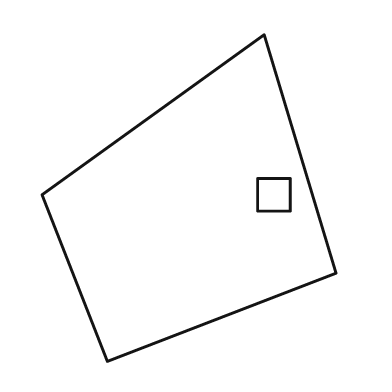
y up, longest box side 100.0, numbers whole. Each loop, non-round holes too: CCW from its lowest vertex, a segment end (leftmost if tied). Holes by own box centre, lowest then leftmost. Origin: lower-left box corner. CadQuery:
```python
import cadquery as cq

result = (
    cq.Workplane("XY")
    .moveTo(20.0, 0.0)
    .lineTo(90.0, 27.0)
    .lineTo(68.0, 100.0)
    .lineTo(0.0, 51.0)
    .close()
    .moveTo(66.0, 46.0)
    .lineTo(76.0, 46.0)
    .lineTo(76.0, 56.0)
    .lineTo(66.0, 56.0)
    .close()
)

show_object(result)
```